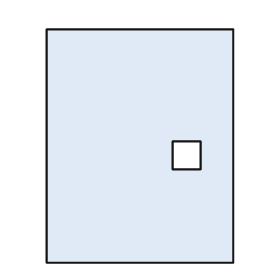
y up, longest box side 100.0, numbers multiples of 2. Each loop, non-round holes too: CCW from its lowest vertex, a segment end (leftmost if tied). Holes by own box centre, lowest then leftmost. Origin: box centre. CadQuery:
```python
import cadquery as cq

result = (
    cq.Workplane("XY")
    .moveTo(-40.0, -50.0)
    .lineTo(40.0, -50.0)
    .lineTo(40.0, 50.0)
    .lineTo(-40.0, 50.0)
    .close()
    .moveTo(14.0, -10.0)
    .lineTo(26.0, -10.0)
    .lineTo(26.0, 2.0)
    .lineTo(14.0, 2.0)
    .close()
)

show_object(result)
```